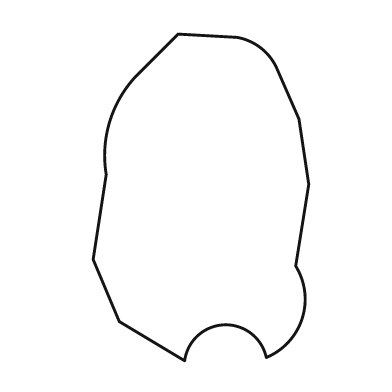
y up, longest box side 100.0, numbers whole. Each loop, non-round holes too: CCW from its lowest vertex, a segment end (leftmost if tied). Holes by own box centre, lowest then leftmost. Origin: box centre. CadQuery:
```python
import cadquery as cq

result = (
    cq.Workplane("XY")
    .moveTo(-5.0, -50.0)
    .threePointArc((7.0, -39.0), (20.0, -49.0))
    .threePointArc((31.0, -37.0), (29.0, -21.0))
    .lineTo(33.0, 4.0)
    .lineTo(30.0, 24.0)
    .lineTo(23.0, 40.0)
    .threePointArc((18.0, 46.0), (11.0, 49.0))
    .lineTo(-7.0, 50.0)
    .lineTo(-20.0, 37.0)
    .threePointArc((-28.0, 23.0), (-29.0, 7.0))
    .lineTo(-33.0, -19.0)
    .lineTo(-25.0, -38.0)
    .close()
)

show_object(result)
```